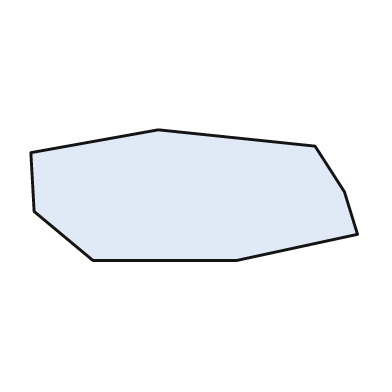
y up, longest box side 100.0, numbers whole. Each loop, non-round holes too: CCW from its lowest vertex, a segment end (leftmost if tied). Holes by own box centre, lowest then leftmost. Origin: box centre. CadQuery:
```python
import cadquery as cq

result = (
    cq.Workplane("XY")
    .moveTo(-31.0, -20.0)
    .lineTo(13.0, -20.0)
    .lineTo(50.0, -12.0)
    .lineTo(46.0, 1.0)
    .lineTo(37.0, 15.0)
    .lineTo(-11.0, 20.0)
    .lineTo(-50.0, 13.0)
    .lineTo(-49.0, -5.0)
    .close()
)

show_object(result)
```